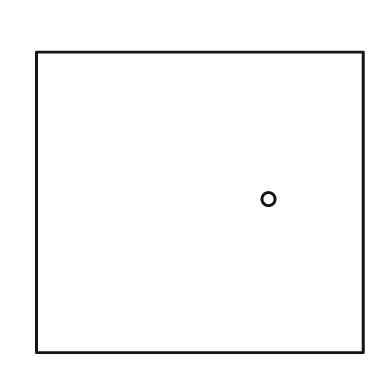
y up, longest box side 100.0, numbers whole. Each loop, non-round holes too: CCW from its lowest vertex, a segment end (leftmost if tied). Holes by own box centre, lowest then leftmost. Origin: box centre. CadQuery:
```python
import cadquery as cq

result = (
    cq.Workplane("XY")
    .moveTo(-50.0, -46.0)
    .lineTo(50.0, -46.0)
    .lineTo(50.0, 46.0)
    .lineTo(-50.0, 46.0)
    .close()
    .moveTo(21.0, 1.0)
    .circle(2.0)
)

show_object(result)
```